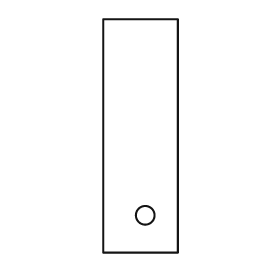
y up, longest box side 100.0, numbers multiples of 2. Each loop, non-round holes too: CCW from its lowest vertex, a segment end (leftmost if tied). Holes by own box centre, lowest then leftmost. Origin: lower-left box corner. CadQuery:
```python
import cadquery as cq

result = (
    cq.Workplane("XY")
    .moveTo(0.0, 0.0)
    .lineTo(32.0, 0.0)
    .lineTo(32.0, 100.0)
    .lineTo(0.0, 100.0)
    .close()
    .moveTo(18.0, 16.0)
    .circle(4.0)
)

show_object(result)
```